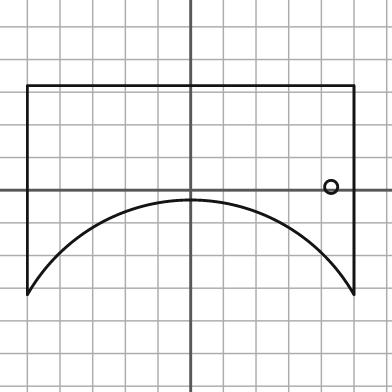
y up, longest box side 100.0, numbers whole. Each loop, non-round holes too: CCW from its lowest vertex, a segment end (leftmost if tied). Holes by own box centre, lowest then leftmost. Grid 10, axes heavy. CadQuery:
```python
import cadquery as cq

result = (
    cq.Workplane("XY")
    .moveTo(-50.0, -32.0)
    .threePointArc((0.0, -3.0), (50.0, -32.0))
    .lineTo(50.0, 32.0)
    .lineTo(-50.0, 32.0)
    .close()
    .moveTo(43.0, 1.0)
    .circle(2.0)
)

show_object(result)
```